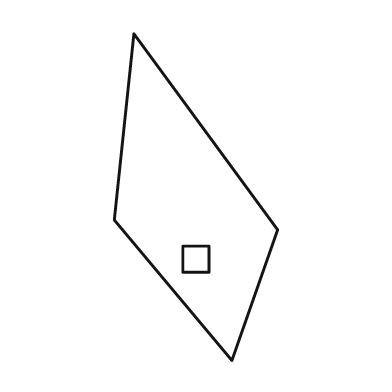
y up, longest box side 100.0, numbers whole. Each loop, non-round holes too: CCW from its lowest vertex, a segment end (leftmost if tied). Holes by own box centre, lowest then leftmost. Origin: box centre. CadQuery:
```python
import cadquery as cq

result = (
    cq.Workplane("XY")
    .moveTo(11.0, -50.0)
    .lineTo(25.0, -10.0)
    .lineTo(-19.0, 50.0)
    .lineTo(-25.0, -7.0)
    .close()
    .moveTo(-4.0, -23.0)
    .lineTo(4.0, -23.0)
    .lineTo(4.0, -15.0)
    .lineTo(-4.0, -15.0)
    .close()
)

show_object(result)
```